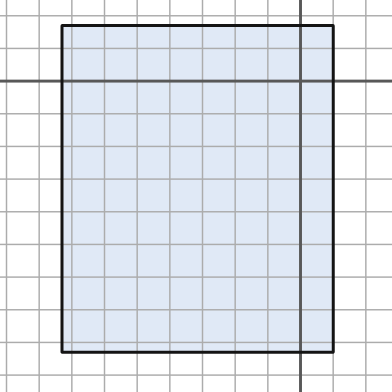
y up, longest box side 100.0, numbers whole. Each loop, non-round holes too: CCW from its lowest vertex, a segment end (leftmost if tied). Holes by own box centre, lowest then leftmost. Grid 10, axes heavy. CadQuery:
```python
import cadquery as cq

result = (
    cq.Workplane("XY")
    .moveTo(-73.0, -83.0)
    .lineTo(10.0, -83.0)
    .lineTo(10.0, 17.0)
    .lineTo(-73.0, 17.0)
    .close()
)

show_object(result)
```